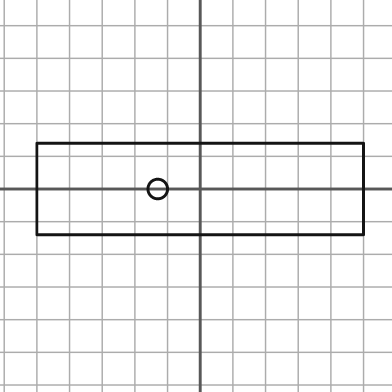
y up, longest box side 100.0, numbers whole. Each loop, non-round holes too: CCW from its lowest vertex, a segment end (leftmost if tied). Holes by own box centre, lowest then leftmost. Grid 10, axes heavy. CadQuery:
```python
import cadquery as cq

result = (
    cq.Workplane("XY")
    .moveTo(-50.0, -14.0)
    .lineTo(50.0, -14.0)
    .lineTo(50.0, 14.0)
    .lineTo(-50.0, 14.0)
    .close()
    .moveTo(-13.0, 0.0)
    .circle(3.0)
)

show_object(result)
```